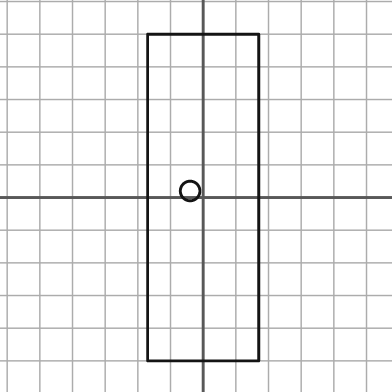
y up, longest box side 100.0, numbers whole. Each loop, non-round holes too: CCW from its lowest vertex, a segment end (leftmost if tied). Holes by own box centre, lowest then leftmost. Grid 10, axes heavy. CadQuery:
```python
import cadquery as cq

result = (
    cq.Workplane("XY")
    .moveTo(-17.0, -50.0)
    .lineTo(17.0, -50.0)
    .lineTo(17.0, 50.0)
    .lineTo(-17.0, 50.0)
    .close()
    .moveTo(-4.0, 2.0)
    .circle(3.0)
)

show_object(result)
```